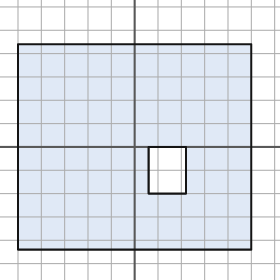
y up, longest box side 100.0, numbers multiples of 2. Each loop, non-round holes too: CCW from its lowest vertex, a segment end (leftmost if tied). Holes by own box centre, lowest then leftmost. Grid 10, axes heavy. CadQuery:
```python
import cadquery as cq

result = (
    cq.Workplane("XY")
    .moveTo(-50.0, -44.0)
    .lineTo(50.0, -44.0)
    .lineTo(50.0, 44.0)
    .lineTo(-50.0, 44.0)
    .close()
    .moveTo(6.0, -20.0)
    .lineTo(22.0, -20.0)
    .lineTo(22.0, 0.0)
    .lineTo(6.0, 0.0)
    .close()
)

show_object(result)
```